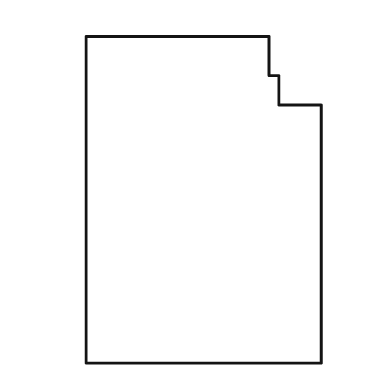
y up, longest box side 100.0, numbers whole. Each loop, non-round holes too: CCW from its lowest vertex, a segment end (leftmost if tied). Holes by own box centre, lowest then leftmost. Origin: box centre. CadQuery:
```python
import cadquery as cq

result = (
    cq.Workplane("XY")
    .moveTo(-36.0, -50.0)
    .lineTo(36.0, -50.0)
    .lineTo(36.0, 29.0)
    .lineTo(23.0, 29.0)
    .lineTo(23.0, 38.0)
    .lineTo(20.0, 38.0)
    .lineTo(20.0, 50.0)
    .lineTo(-36.0, 50.0)
    .close()
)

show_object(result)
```